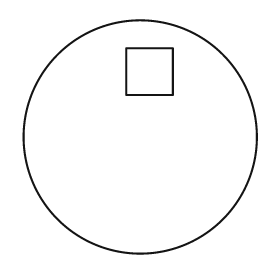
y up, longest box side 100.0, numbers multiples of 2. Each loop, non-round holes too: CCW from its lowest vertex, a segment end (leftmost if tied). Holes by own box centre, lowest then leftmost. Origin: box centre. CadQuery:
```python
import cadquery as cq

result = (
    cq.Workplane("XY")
    .moveTo(0.0, 0.0)
    .circle(50.0)
    .moveTo(-6.0, 18.0)
    .lineTo(14.0, 18.0)
    .lineTo(14.0, 38.0)
    .lineTo(-6.0, 38.0)
    .close()
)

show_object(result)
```